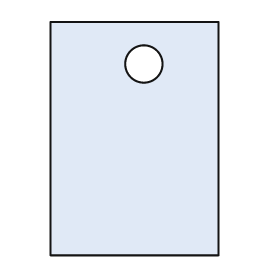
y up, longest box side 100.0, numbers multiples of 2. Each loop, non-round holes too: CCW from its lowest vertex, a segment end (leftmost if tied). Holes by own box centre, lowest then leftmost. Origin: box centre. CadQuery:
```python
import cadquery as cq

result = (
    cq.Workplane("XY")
    .moveTo(-36.0, -50.0)
    .lineTo(36.0, -50.0)
    .lineTo(36.0, 50.0)
    .lineTo(-36.0, 50.0)
    .close()
    .moveTo(4.0, 32.0)
    .circle(8.0)
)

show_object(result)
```